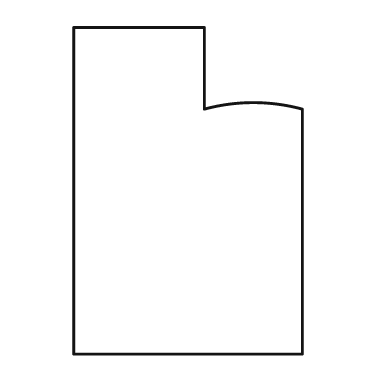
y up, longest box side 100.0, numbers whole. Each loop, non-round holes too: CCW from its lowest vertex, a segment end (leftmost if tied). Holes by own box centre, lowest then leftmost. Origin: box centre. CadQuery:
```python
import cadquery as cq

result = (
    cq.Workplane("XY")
    .moveTo(-35.0, -50.0)
    .lineTo(35.0, -50.0)
    .lineTo(35.0, 25.0)
    .threePointArc((20.0, 27.0), (5.0, 25.0))
    .lineTo(5.0, 50.0)
    .lineTo(-35.0, 50.0)
    .close()
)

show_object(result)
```